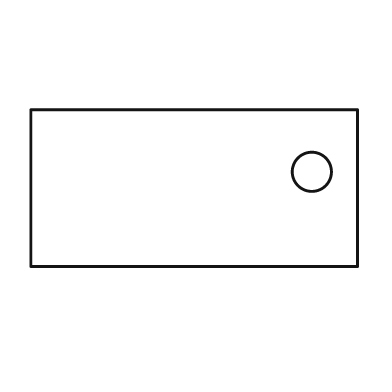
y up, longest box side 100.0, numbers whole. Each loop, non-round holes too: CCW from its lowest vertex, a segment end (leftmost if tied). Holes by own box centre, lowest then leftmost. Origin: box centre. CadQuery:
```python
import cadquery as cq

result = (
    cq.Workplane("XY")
    .moveTo(-50.0, -24.0)
    .lineTo(50.0, -24.0)
    .lineTo(50.0, 24.0)
    .lineTo(-50.0, 24.0)
    .close()
    .moveTo(36.0, 5.0)
    .circle(6.0)
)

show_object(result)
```